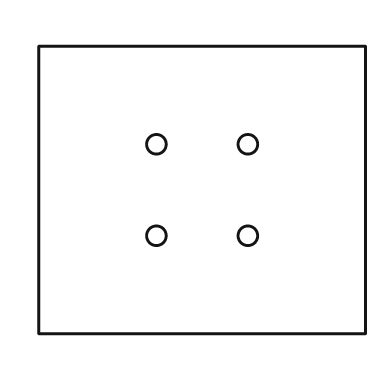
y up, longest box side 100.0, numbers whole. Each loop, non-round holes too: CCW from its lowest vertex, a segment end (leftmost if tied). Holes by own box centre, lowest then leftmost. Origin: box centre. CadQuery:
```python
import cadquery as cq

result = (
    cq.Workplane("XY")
    .moveTo(-50.0, -44.0)
    .lineTo(50.0, -44.0)
    .lineTo(50.0, 44.0)
    .lineTo(-50.0, 44.0)
    .close()
    .moveTo(-14.0, -14.0)
    .circle(3.0)
    .moveTo(14.0, -14.0)
    .circle(3.0)
    .moveTo(-14.0, 14.0)
    .circle(3.0)
    .moveTo(14.0, 14.0)
    .circle(3.0)
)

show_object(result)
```